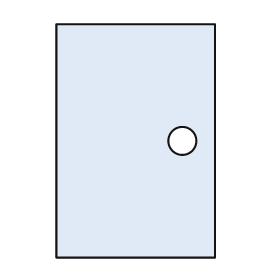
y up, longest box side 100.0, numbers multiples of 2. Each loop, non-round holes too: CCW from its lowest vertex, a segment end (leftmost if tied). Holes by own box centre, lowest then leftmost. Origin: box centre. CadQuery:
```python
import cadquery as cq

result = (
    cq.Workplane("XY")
    .moveTo(-34.0, -50.0)
    .lineTo(34.0, -50.0)
    .lineTo(34.0, 50.0)
    .lineTo(-34.0, 50.0)
    .close()
    .moveTo(20.0, 0.0)
    .circle(6.0)
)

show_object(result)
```